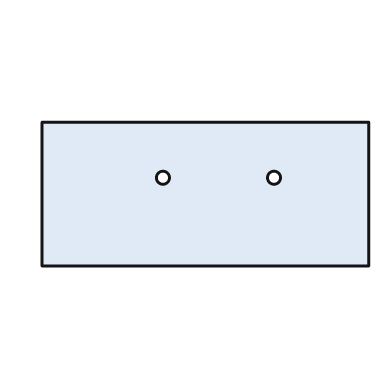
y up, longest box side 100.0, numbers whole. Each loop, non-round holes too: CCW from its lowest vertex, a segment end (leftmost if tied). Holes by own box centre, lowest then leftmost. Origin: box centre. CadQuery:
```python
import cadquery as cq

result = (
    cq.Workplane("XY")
    .moveTo(-50.0, -22.0)
    .lineTo(50.0, -22.0)
    .lineTo(50.0, 22.0)
    .lineTo(-50.0, 22.0)
    .close()
    .moveTo(-13.0, 5.0)
    .circle(2.0)
    .moveTo(21.0, 5.0)
    .circle(2.0)
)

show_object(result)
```